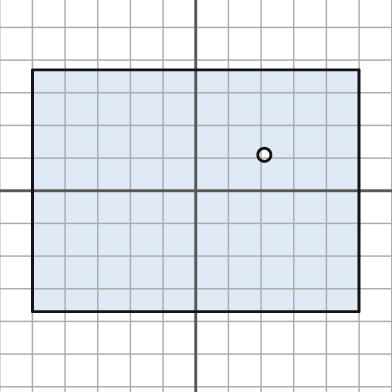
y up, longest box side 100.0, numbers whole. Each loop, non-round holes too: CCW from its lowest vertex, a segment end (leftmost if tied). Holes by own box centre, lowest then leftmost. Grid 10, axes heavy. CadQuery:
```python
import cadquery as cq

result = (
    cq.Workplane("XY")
    .moveTo(-50.0, -37.0)
    .lineTo(50.0, -37.0)
    .lineTo(50.0, 37.0)
    .lineTo(-50.0, 37.0)
    .close()
    .moveTo(21.0, 11.0)
    .circle(2.0)
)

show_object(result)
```